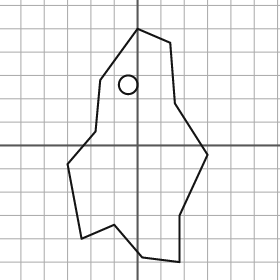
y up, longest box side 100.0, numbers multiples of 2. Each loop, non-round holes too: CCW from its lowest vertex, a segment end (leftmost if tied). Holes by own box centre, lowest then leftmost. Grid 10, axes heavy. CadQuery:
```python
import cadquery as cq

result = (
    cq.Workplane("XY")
    .moveTo(18.0, -50.0)
    .lineTo(18.0, -30.0)
    .lineTo(30.0, -4.0)
    .lineTo(16.0, 18.0)
    .lineTo(14.0, 44.0)
    .lineTo(0.0, 50.0)
    .lineTo(-16.0, 28.0)
    .lineTo(-18.0, 6.0)
    .lineTo(-30.0, -8.0)
    .lineTo(-24.0, -40.0)
    .lineTo(-10.0, -34.0)
    .lineTo(2.0, -48.0)
    .close()
    .moveTo(-4.0, 26.0)
    .circle(4.0)
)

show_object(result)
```